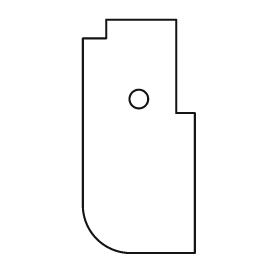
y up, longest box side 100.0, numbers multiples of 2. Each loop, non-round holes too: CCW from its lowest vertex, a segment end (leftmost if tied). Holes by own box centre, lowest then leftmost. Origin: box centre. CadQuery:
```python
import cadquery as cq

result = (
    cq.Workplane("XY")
    .moveTo(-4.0, -50.0)
    .lineTo(24.0, -50.0)
    .lineTo(24.0, 10.0)
    .lineTo(16.0, 10.0)
    .lineTo(16.0, 50.0)
    .lineTo(-14.0, 50.0)
    .lineTo(-14.0, 42.0)
    .lineTo(-24.0, 42.0)
    .lineTo(-24.0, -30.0)
    .threePointArc((-18.0, -44.0), (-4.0, -50.0))
    .close()
    .moveTo(0.0, 16.0)
    .circle(4.0)
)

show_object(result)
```